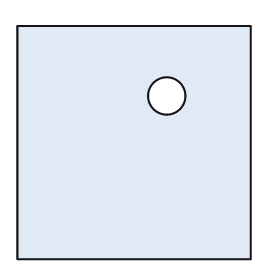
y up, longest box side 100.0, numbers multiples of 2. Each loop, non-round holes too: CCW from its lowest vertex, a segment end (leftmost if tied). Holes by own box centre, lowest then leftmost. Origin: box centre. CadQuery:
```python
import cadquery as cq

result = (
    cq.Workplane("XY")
    .moveTo(-50.0, -50.0)
    .lineTo(50.0, -50.0)
    .lineTo(50.0, 50.0)
    .lineTo(-50.0, 50.0)
    .close()
    .moveTo(14.0, 20.0)
    .circle(8.0)
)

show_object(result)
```